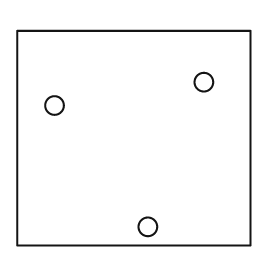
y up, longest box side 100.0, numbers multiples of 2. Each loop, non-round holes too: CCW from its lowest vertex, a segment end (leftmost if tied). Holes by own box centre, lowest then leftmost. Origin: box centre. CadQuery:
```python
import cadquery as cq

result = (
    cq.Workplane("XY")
    .moveTo(-50.0, -46.0)
    .lineTo(50.0, -46.0)
    .lineTo(50.0, 46.0)
    .lineTo(-50.0, 46.0)
    .close()
    .moveTo(6.0, -38.0)
    .circle(4.0)
    .moveTo(-34.0, 14.0)
    .circle(4.0)
    .moveTo(30.0, 24.0)
    .circle(4.0)
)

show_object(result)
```